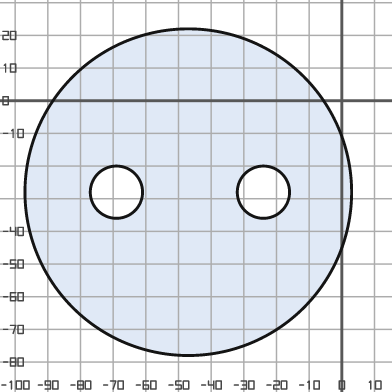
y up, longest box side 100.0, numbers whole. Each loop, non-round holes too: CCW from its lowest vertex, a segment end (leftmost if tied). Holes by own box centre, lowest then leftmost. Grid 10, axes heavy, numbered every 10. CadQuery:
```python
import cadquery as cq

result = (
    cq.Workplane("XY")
    .moveTo(-47.0, -28.0)
    .circle(50.0)
    .moveTo(-69.0, -28.0)
    .circle(8.0)
    .moveTo(-24.0, -28.0)
    .circle(8.0)
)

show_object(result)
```